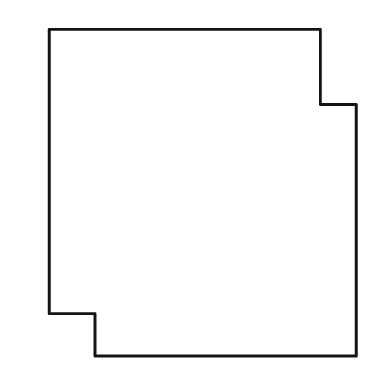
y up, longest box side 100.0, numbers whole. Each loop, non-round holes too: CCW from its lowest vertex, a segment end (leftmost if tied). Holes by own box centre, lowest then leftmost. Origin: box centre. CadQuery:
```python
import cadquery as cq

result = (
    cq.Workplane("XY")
    .moveTo(-33.0, -50.0)
    .lineTo(47.0, -50.0)
    .lineTo(47.0, 27.0)
    .lineTo(36.0, 27.0)
    .lineTo(36.0, 50.0)
    .lineTo(-47.0, 50.0)
    .lineTo(-47.0, -37.0)
    .lineTo(-33.0, -37.0)
    .close()
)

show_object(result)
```